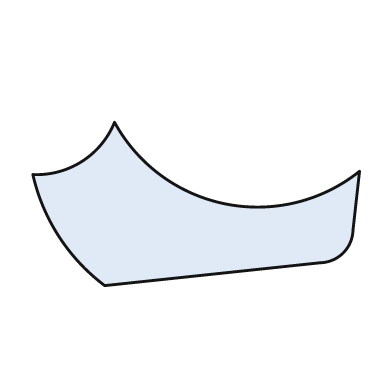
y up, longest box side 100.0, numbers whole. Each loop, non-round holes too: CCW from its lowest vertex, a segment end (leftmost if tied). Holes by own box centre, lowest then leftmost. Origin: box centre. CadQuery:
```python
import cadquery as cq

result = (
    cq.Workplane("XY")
    .moveTo(-28.0, -25.0)
    .lineTo(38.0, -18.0)
    .threePointArc((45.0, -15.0), (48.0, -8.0))
    .lineTo(50.0, 10.0)
    .threePointArc((9.0, 0.0), (-25.0, 25.0))
    .threePointArc((-35.0, 13.0), (-50.0, 9.0))
    .threePointArc((-42.0, -10.0), (-28.0, -25.0))
    .close()
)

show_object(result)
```